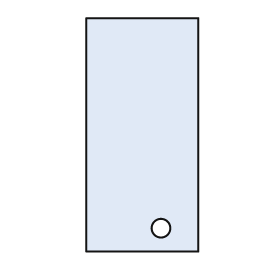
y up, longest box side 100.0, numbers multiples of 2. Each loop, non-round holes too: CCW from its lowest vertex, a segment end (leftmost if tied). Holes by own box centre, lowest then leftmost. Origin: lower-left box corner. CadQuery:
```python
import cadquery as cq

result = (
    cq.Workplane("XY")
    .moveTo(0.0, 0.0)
    .lineTo(48.0, 0.0)
    .lineTo(48.0, 100.0)
    .lineTo(0.0, 100.0)
    .close()
    .moveTo(32.0, 10.0)
    .circle(4.0)
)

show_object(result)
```